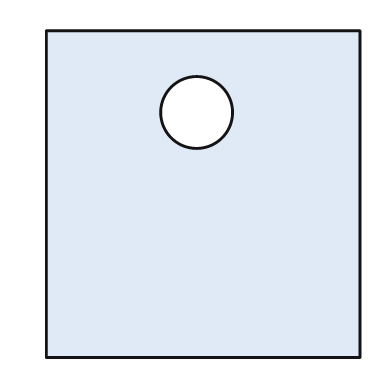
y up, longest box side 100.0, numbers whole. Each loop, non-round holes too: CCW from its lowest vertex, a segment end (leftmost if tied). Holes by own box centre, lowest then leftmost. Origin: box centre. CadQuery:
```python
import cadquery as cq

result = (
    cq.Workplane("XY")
    .moveTo(-48.0, -50.0)
    .lineTo(48.0, -50.0)
    .lineTo(48.0, 50.0)
    .lineTo(-48.0, 50.0)
    .close()
    .moveTo(-2.0, 25.0)
    .circle(11.0)
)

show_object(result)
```